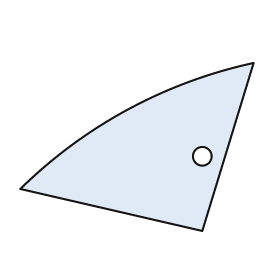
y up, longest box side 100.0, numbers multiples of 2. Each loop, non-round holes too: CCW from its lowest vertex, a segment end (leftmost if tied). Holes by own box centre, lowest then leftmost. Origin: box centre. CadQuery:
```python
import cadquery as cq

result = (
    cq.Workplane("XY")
    .moveTo(28.0, -36.0)
    .lineTo(50.0, 36.0)
    .threePointArc((-4.0, 16.0), (-50.0, -18.0))
    .close()
    .moveTo(28.0, -4.0)
    .circle(4.0)
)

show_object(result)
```